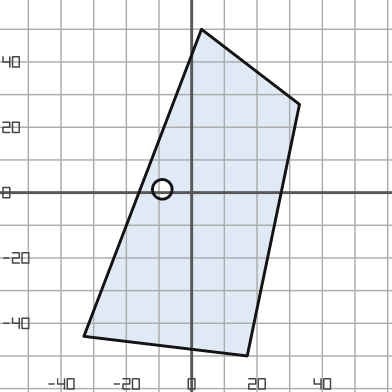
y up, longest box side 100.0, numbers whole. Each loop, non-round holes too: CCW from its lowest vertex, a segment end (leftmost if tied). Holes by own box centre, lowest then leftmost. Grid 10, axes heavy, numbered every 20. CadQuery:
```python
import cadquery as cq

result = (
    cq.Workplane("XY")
    .moveTo(17.0, -50.0)
    .lineTo(33.0, 27.0)
    .lineTo(3.0, 50.0)
    .lineTo(-33.0, -44.0)
    .close()
    .moveTo(-9.0, 1.0)
    .circle(3.0)
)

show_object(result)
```